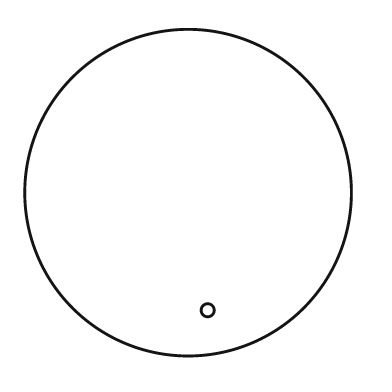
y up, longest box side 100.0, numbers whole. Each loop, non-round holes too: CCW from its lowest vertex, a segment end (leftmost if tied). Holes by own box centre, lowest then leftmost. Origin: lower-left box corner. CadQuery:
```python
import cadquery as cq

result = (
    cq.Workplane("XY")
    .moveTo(50.0, 50.0)
    .circle(50.0)
    .moveTo(56.0, 14.0)
    .circle(2.0)
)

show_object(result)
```